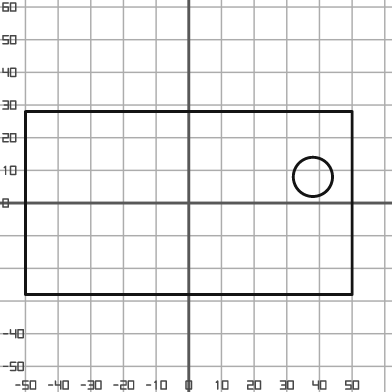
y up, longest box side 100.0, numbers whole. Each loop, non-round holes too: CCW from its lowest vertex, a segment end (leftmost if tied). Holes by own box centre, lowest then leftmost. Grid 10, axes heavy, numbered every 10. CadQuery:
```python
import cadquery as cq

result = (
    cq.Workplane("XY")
    .moveTo(-50.0, -28.0)
    .lineTo(50.0, -28.0)
    .lineTo(50.0, 28.0)
    .lineTo(-50.0, 28.0)
    .close()
    .moveTo(38.0, 8.0)
    .circle(6.0)
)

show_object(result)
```